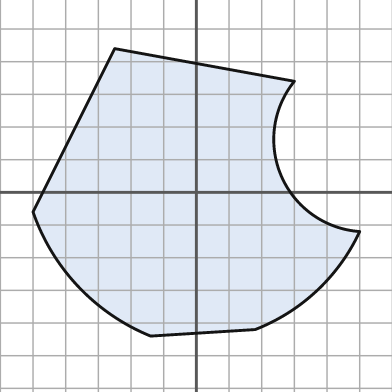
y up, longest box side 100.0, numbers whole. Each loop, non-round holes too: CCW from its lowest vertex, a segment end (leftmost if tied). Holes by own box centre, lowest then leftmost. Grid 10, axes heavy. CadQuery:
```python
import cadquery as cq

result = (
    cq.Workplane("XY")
    .moveTo(-14.0, -44.0)
    .lineTo(18.0, -42.0)
    .threePointArc((37.0, -30.0), (50.0, -12.0))
    .threePointArc((26.0, 5.0), (30.0, 34.0))
    .lineTo(-25.0, 44.0)
    .lineTo(-50.0, -6.0)
    .threePointArc((-36.0, -29.0), (-14.0, -44.0))
    .close()
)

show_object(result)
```